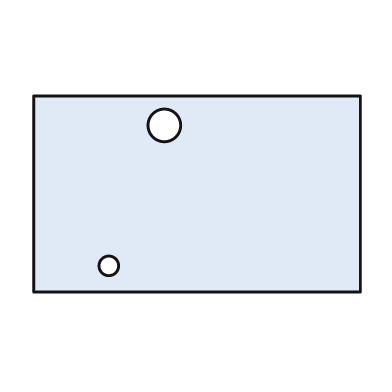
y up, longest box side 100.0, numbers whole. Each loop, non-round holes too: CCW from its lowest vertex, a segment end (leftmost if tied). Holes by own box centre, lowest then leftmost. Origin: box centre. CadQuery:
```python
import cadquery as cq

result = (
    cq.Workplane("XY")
    .moveTo(-50.0, -30.0)
    .lineTo(50.0, -30.0)
    .lineTo(50.0, 30.0)
    .lineTo(-50.0, 30.0)
    .close()
    .moveTo(-27.0, -22.0)
    .circle(3.0)
    .moveTo(-10.0, 21.0)
    .circle(5.0)
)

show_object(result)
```